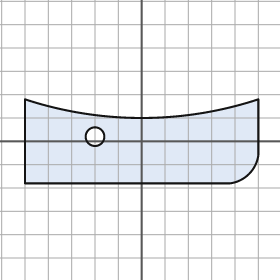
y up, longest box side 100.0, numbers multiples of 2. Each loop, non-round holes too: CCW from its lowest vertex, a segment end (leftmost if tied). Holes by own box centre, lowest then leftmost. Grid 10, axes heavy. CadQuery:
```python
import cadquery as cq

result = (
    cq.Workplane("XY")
    .moveTo(-50.0, -18.0)
    .lineTo(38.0, -18.0)
    .threePointArc((46.0, -14.0), (50.0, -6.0))
    .lineTo(50.0, 18.0)
    .threePointArc((0.0, 10.0), (-50.0, 18.0))
    .close()
    .moveTo(-20.0, 2.0)
    .circle(4.0)
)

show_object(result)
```